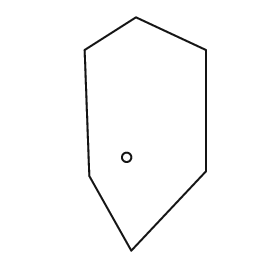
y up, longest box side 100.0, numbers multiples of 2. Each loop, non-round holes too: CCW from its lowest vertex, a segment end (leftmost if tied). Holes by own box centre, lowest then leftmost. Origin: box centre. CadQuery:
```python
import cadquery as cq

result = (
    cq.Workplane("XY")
    .moveTo(-6.0, -50.0)
    .lineTo(26.0, -16.0)
    .lineTo(26.0, 36.0)
    .lineTo(-4.0, 50.0)
    .lineTo(-26.0, 36.0)
    .lineTo(-24.0, -18.0)
    .close()
    .moveTo(-8.0, -10.0)
    .circle(2.0)
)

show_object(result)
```